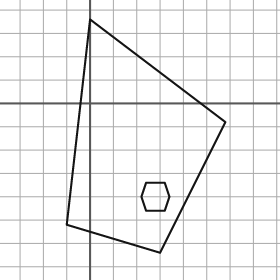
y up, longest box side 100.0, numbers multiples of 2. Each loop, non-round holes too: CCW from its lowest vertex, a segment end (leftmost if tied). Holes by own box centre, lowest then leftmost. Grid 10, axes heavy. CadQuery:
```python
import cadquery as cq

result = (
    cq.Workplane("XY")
    .moveTo(30.0, -64.0)
    .lineTo(58.0, -8.0)
    .lineTo(0.0, 36.0)
    .lineTo(-10.0, -52.0)
    .close()
    .moveTo(24.0, -46.0)
    .lineTo(32.0, -46.0)
    .lineTo(34.0, -40.0)
    .lineTo(32.0, -34.0)
    .lineTo(24.0, -34.0)
    .lineTo(22.0, -40.0)
    .close()
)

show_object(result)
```